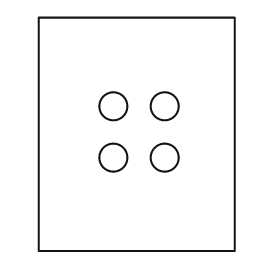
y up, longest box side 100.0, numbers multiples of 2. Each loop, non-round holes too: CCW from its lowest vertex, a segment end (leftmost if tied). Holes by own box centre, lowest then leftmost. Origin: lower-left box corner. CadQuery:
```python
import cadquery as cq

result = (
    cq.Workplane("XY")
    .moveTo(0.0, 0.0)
    .lineTo(84.0, 0.0)
    .lineTo(84.0, 100.0)
    .lineTo(0.0, 100.0)
    .close()
    .moveTo(32.0, 40.0)
    .circle(6.0)
    .moveTo(54.0, 40.0)
    .circle(6.0)
    .moveTo(32.0, 62.0)
    .circle(6.0)
    .moveTo(54.0, 62.0)
    .circle(6.0)
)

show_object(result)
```